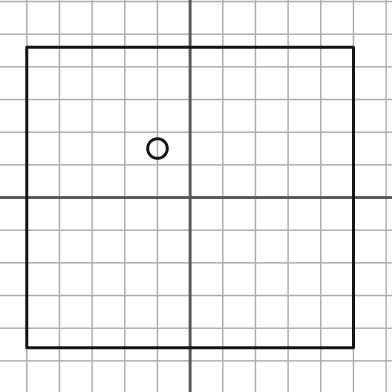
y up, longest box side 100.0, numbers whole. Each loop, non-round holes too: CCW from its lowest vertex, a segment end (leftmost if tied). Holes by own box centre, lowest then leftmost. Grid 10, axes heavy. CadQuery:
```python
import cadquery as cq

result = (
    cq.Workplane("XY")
    .moveTo(-50.0, -46.0)
    .lineTo(50.0, -46.0)
    .lineTo(50.0, 46.0)
    .lineTo(-50.0, 46.0)
    .close()
    .moveTo(-10.0, 15.0)
    .circle(3.0)
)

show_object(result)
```